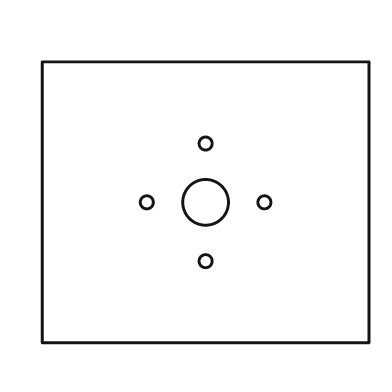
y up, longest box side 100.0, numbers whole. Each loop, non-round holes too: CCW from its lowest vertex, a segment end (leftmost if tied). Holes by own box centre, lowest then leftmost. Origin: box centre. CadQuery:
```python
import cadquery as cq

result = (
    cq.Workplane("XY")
    .moveTo(-50.0, -43.0)
    .lineTo(50.0, -43.0)
    .lineTo(50.0, 43.0)
    .lineTo(-50.0, 43.0)
    .close()
    .moveTo(0.0, -18.0)
    .circle(2.0)
    .moveTo(-18.0, 0.0)
    .circle(2.0)
    .moveTo(0.0, 0.0)
    .circle(7.0)
    .moveTo(18.0, 0.0)
    .circle(2.0)
    .moveTo(0.0, 18.0)
    .circle(2.0)
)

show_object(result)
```